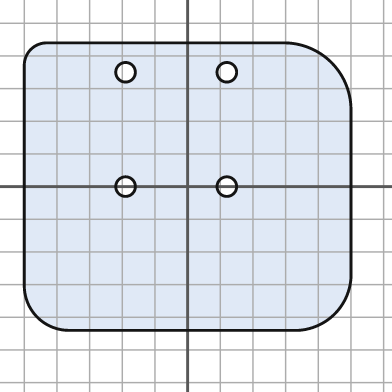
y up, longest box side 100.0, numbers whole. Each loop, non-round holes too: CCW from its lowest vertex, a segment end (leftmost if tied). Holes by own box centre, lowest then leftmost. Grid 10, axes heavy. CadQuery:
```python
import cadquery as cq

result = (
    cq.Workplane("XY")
    .moveTo(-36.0, -44.0)
    .lineTo(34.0, -44.0)
    .threePointArc((45.0, -39.0), (50.0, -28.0))
    .lineTo(50.0, 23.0)
    .threePointArc((44.0, 38.0), (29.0, 44.0))
    .lineTo(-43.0, 44.0)
    .threePointArc((-48.0, 42.0), (-50.0, 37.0))
    .lineTo(-50.0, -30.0)
    .threePointArc((-46.0, -40.0), (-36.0, -44.0))
    .close()
    .moveTo(-19.0, 0.0)
    .circle(3.0)
    .moveTo(12.0, 0.0)
    .circle(3.0)
    .moveTo(-19.0, 35.0)
    .circle(3.0)
    .moveTo(12.0, 35.0)
    .circle(3.0)
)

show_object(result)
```